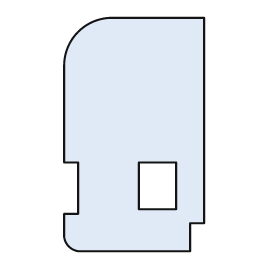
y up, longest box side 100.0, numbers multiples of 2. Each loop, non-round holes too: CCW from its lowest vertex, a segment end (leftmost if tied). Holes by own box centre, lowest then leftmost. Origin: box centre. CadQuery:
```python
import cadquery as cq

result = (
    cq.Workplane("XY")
    .moveTo(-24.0, -50.0)
    .lineTo(24.0, -50.0)
    .lineTo(24.0, -38.0)
    .lineTo(30.0, -38.0)
    .lineTo(30.0, 50.0)
    .lineTo(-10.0, 50.0)
    .threePointArc((-24.0, 44.0), (-30.0, 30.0))
    .lineTo(-30.0, -12.0)
    .lineTo(-24.0, -12.0)
    .lineTo(-24.0, -34.0)
    .lineTo(-30.0, -34.0)
    .lineTo(-30.0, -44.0)
    .threePointArc((-28.0, -48.0), (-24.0, -50.0))
    .close()
    .moveTo(2.0, -32.0)
    .lineTo(18.0, -32.0)
    .lineTo(18.0, -12.0)
    .lineTo(2.0, -12.0)
    .close()
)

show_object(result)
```